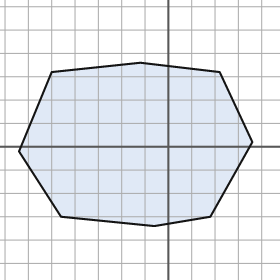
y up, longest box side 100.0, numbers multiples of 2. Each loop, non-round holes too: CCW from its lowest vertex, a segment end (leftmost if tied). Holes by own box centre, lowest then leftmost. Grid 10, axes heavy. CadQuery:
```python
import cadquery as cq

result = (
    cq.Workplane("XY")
    .moveTo(-6.0, -34.0)
    .lineTo(18.0, -30.0)
    .lineTo(36.0, 2.0)
    .lineTo(22.0, 32.0)
    .lineTo(-12.0, 36.0)
    .lineTo(-50.0, 32.0)
    .lineTo(-64.0, -2.0)
    .lineTo(-46.0, -30.0)
    .close()
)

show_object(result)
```